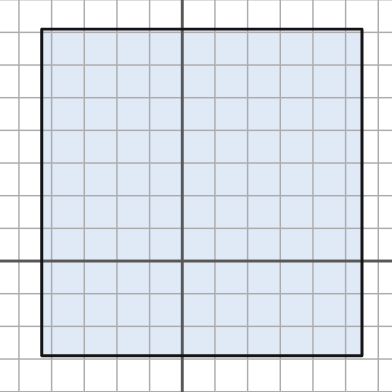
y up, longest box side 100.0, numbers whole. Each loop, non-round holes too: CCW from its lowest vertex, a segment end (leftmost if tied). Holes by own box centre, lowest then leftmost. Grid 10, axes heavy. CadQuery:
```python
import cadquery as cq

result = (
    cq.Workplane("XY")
    .moveTo(-43.0, -29.0)
    .lineTo(55.0, -29.0)
    .lineTo(55.0, 71.0)
    .lineTo(-43.0, 71.0)
    .close()
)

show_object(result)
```